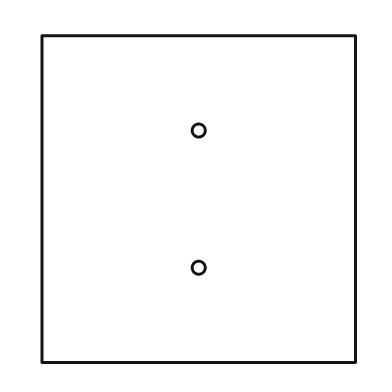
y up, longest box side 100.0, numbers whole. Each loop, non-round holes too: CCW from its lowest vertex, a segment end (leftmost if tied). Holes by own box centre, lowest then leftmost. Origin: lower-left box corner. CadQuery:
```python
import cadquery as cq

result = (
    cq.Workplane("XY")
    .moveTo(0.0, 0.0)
    .lineTo(96.0, 0.0)
    .lineTo(96.0, 100.0)
    .lineTo(0.0, 100.0)
    .close()
    .moveTo(48.0, 29.0)
    .circle(2.0)
    .moveTo(48.0, 71.0)
    .circle(2.0)
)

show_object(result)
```